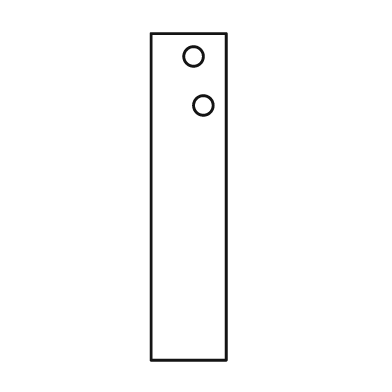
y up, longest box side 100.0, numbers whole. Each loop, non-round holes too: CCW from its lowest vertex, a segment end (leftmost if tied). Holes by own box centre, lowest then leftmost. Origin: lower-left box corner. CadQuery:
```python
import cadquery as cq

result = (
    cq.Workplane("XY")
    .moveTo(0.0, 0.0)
    .lineTo(23.0, 0.0)
    .lineTo(23.0, 100.0)
    .lineTo(0.0, 100.0)
    .close()
    .moveTo(16.0, 78.0)
    .circle(3.0)
    .moveTo(13.0, 93.0)
    .circle(3.0)
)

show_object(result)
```